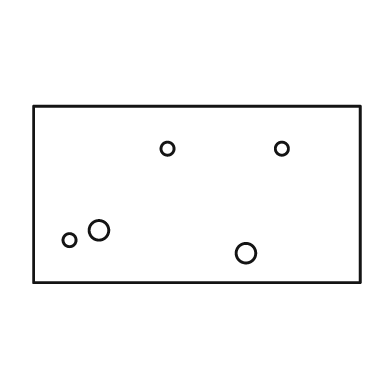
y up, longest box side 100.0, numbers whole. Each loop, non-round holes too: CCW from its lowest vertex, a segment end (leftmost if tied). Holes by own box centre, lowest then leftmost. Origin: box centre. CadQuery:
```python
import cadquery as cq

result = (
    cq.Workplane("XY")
    .moveTo(-50.0, -27.0)
    .lineTo(50.0, -27.0)
    .lineTo(50.0, 27.0)
    .lineTo(-50.0, 27.0)
    .close()
    .moveTo(15.0, -18.0)
    .circle(3.0)
    .moveTo(-39.0, -14.0)
    .circle(2.0)
    .moveTo(-30.0, -11.0)
    .circle(3.0)
    .moveTo(-9.0, 14.0)
    .circle(2.0)
    .moveTo(26.0, 14.0)
    .circle(2.0)
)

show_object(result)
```